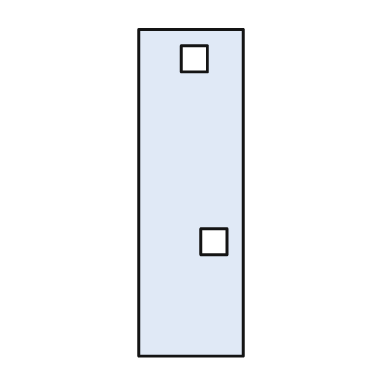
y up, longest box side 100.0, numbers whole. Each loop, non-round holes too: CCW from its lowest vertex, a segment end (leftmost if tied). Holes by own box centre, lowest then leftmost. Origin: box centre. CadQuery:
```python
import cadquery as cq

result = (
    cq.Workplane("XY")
    .moveTo(-16.0, -50.0)
    .lineTo(16.0, -50.0)
    .lineTo(16.0, 50.0)
    .lineTo(-16.0, 50.0)
    .close()
    .moveTo(3.0, -19.0)
    .lineTo(11.0, -19.0)
    .lineTo(11.0, -11.0)
    .lineTo(3.0, -11.0)
    .close()
    .moveTo(-3.0, 37.0)
    .lineTo(5.0, 37.0)
    .lineTo(5.0, 45.0)
    .lineTo(-3.0, 45.0)
    .close()
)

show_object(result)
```